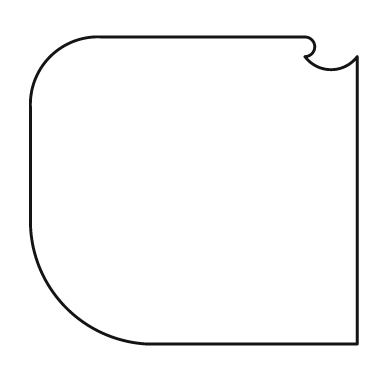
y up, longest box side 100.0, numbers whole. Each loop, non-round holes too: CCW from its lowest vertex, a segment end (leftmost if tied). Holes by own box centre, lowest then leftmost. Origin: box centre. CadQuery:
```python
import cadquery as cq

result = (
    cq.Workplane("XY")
    .moveTo(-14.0, -47.0)
    .lineTo(50.0, -47.0)
    .lineTo(50.0, 41.0)
    .threePointArc((42.0, 37.0), (34.0, 41.0))
    .threePointArc((37.0, 44.0), (34.0, 47.0))
    .lineTo(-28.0, 47.0)
    .threePointArc((-44.0, 41.0), (-50.0, 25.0))
    .lineTo(-50.0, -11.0)
    .threePointArc((-39.0, -36.0), (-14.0, -47.0))
    .close()
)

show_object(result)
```